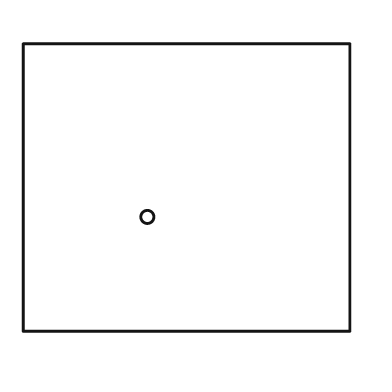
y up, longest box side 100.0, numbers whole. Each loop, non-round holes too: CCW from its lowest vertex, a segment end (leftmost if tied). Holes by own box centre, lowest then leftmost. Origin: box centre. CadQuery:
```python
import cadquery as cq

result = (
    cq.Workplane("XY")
    .moveTo(-50.0, -44.0)
    .lineTo(50.0, -44.0)
    .lineTo(50.0, 44.0)
    .lineTo(-50.0, 44.0)
    .close()
    .moveTo(-12.0, -9.0)
    .circle(2.0)
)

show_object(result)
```